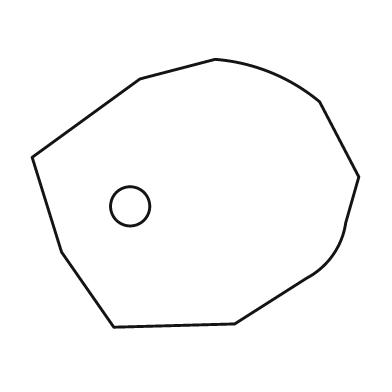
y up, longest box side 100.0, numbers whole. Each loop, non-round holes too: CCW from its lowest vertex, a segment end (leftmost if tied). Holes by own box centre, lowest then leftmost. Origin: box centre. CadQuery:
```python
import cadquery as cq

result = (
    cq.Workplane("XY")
    .moveTo(-25.0, -41.0)
    .lineTo(12.0, -40.0)
    .lineTo(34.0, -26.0)
    .threePointArc((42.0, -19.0), (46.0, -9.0))
    .lineTo(50.0, 5.0)
    .lineTo(38.0, 28.0)
    .threePointArc((23.0, 37.0), (6.0, 41.0))
    .lineTo(-17.0, 35.0)
    .lineTo(-50.0, 11.0)
    .lineTo(-41.0, -18.0)
    .close()
    .moveTo(-20.0, -4.0)
    .circle(6.0)
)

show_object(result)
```